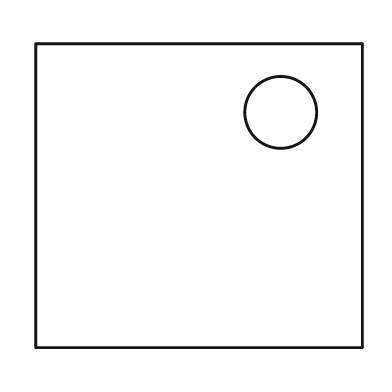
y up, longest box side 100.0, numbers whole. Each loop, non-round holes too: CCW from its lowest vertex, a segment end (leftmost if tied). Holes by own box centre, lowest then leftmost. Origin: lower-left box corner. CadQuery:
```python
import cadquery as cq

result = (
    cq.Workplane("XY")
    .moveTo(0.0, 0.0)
    .lineTo(100.0, 0.0)
    .lineTo(100.0, 93.0)
    .lineTo(0.0, 93.0)
    .close()
    .moveTo(75.0, 72.0)
    .circle(11.0)
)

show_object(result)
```